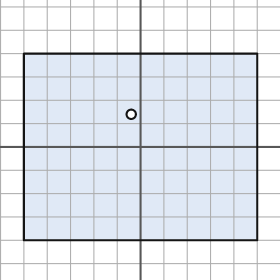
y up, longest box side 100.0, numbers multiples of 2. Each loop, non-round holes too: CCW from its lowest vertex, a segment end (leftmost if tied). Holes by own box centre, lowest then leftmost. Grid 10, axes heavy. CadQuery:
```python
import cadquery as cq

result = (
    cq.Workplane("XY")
    .moveTo(-50.0, -40.0)
    .lineTo(50.0, -40.0)
    .lineTo(50.0, 40.0)
    .lineTo(-50.0, 40.0)
    .close()
    .moveTo(-4.0, 14.0)
    .circle(2.0)
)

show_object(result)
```